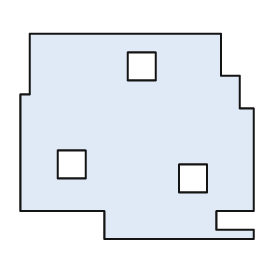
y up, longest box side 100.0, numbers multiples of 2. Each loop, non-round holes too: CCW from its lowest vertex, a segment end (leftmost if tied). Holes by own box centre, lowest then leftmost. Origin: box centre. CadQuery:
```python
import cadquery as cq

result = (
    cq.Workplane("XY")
    .moveTo(-14.0, -44.0)
    .lineTo(50.0, -44.0)
    .lineTo(50.0, -40.0)
    .lineTo(34.0, -40.0)
    .lineTo(34.0, -32.0)
    .lineTo(50.0, -32.0)
    .lineTo(50.0, 12.0)
    .lineTo(44.0, 12.0)
    .lineTo(44.0, 26.0)
    .lineTo(36.0, 26.0)
    .lineTo(36.0, 44.0)
    .lineTo(-46.0, 44.0)
    .lineTo(-46.0, 18.0)
    .lineTo(-50.0, 18.0)
    .lineTo(-50.0, -32.0)
    .lineTo(-14.0, -32.0)
    .close()
    .moveTo(18.0, -24.0)
    .lineTo(30.0, -24.0)
    .lineTo(30.0, -12.0)
    .lineTo(18.0, -12.0)
    .close()
    .moveTo(-34.0, -18.0)
    .lineTo(-22.0, -18.0)
    .lineTo(-22.0, -6.0)
    .lineTo(-34.0, -6.0)
    .close()
    .moveTo(-4.0, 24.0)
    .lineTo(8.0, 24.0)
    .lineTo(8.0, 36.0)
    .lineTo(-4.0, 36.0)
    .close()
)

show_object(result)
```